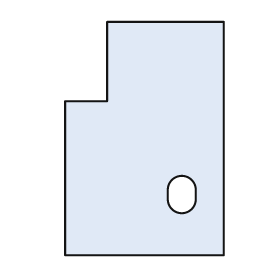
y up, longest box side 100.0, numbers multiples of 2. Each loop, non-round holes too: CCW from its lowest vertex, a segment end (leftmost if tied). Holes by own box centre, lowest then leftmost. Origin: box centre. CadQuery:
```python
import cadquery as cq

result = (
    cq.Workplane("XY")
    .moveTo(-34.0, -50.0)
    .lineTo(34.0, -50.0)
    .lineTo(34.0, 50.0)
    .lineTo(-16.0, 50.0)
    .lineTo(-16.0, 16.0)
    .lineTo(-34.0, 16.0)
    .close()
    .moveTo(10.0, -26.0)
    .threePointArc((16.0, -32.0), (22.0, -26.0))
    .lineTo(22.0, -22.0)
    .threePointArc((16.0, -16.0), (10.0, -22.0))
    .close()
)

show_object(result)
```